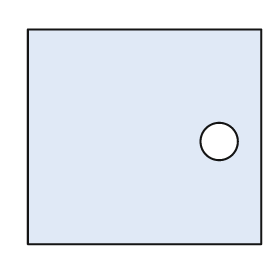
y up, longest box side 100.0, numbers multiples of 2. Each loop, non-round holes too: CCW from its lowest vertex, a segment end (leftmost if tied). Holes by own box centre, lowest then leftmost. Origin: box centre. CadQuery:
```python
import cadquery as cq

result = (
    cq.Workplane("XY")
    .moveTo(-50.0, -46.0)
    .lineTo(50.0, -46.0)
    .lineTo(50.0, 46.0)
    .lineTo(-50.0, 46.0)
    .close()
    .moveTo(32.0, -2.0)
    .circle(8.0)
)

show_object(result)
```